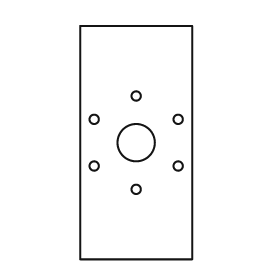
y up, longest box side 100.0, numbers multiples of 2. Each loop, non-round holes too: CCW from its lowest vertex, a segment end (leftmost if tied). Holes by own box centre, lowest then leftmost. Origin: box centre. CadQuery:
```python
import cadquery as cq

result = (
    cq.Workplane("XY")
    .moveTo(-24.0, -50.0)
    .lineTo(24.0, -50.0)
    .lineTo(24.0, 50.0)
    .lineTo(-24.0, 50.0)
    .close()
    .moveTo(0.0, -20.0)
    .circle(2.0)
    .moveTo(-18.0, -10.0)
    .circle(2.0)
    .moveTo(18.0, -10.0)
    .circle(2.0)
    .moveTo(0.0, 0.0)
    .circle(8.0)
    .moveTo(-18.0, 10.0)
    .circle(2.0)
    .moveTo(18.0, 10.0)
    .circle(2.0)
    .moveTo(0.0, 20.0)
    .circle(2.0)
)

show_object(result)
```